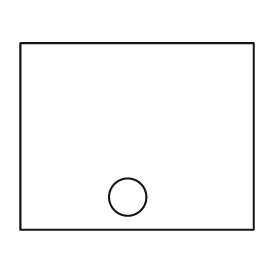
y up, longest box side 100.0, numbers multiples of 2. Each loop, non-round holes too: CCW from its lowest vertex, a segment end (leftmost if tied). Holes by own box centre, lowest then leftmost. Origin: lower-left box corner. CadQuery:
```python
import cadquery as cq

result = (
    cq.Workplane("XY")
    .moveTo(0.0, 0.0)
    .lineTo(100.0, 0.0)
    .lineTo(100.0, 80.0)
    .lineTo(0.0, 80.0)
    .close()
    .moveTo(46.0, 14.0)
    .circle(8.0)
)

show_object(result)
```